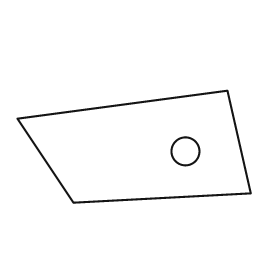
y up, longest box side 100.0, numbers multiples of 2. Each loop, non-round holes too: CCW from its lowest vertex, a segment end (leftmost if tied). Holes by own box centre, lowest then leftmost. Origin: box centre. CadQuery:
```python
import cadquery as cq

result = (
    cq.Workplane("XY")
    .moveTo(-26.0, -24.0)
    .lineTo(50.0, -20.0)
    .lineTo(40.0, 24.0)
    .lineTo(-50.0, 12.0)
    .close()
    .moveTo(22.0, -2.0)
    .circle(6.0)
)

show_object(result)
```